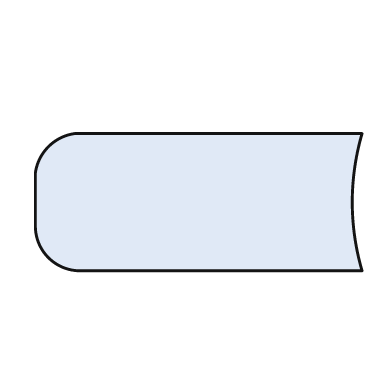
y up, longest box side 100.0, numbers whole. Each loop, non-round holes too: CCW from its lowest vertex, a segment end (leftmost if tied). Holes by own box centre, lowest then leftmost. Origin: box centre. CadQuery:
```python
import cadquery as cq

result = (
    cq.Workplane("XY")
    .moveTo(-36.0, -21.0)
    .lineTo(50.0, -21.0)
    .threePointArc((47.0, 0.0), (50.0, 21.0))
    .lineTo(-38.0, 21.0)
    .threePointArc((-46.0, 17.0), (-50.0, 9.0))
    .lineTo(-50.0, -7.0)
    .threePointArc((-46.0, -17.0), (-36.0, -21.0))
    .close()
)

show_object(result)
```